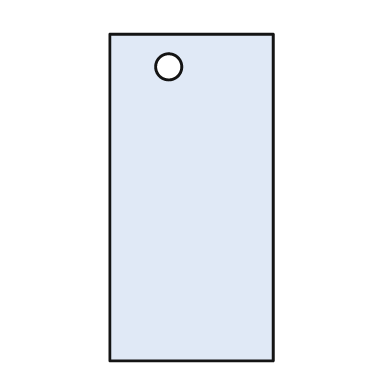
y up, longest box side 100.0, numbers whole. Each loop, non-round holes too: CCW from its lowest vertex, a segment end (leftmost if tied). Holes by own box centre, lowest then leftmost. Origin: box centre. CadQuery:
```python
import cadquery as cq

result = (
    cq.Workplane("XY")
    .moveTo(-25.0, -50.0)
    .lineTo(25.0, -50.0)
    .lineTo(25.0, 50.0)
    .lineTo(-25.0, 50.0)
    .close()
    .moveTo(-7.0, 40.0)
    .circle(4.0)
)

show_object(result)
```